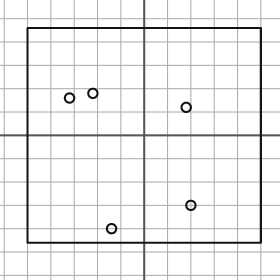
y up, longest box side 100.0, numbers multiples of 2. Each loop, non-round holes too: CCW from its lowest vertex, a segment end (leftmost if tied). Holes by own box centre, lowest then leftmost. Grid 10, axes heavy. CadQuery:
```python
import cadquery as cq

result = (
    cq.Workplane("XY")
    .moveTo(-50.0, -46.0)
    .lineTo(50.0, -46.0)
    .lineTo(50.0, 46.0)
    .lineTo(-50.0, 46.0)
    .close()
    .moveTo(-14.0, -40.0)
    .circle(2.0)
    .moveTo(20.0, -30.0)
    .circle(2.0)
    .moveTo(18.0, 12.0)
    .circle(2.0)
    .moveTo(-32.0, 16.0)
    .circle(2.0)
    .moveTo(-22.0, 18.0)
    .circle(2.0)
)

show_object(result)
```